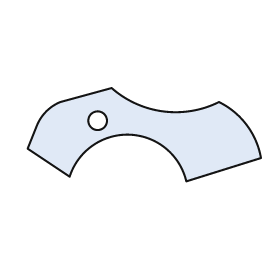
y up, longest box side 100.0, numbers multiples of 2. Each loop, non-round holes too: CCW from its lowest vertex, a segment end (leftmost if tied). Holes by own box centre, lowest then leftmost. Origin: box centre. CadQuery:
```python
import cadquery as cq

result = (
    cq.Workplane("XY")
    .moveTo(18.0, -20.0)
    .lineTo(50.0, -10.0)
    .threePointArc((44.0, 4.0), (32.0, 14.0))
    .threePointArc((8.0, 10.0), (-14.0, 20.0))
    .lineTo(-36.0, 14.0)
    .threePointArc((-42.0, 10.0), (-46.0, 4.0))
    .lineTo(-50.0, -6.0)
    .lineTo(-32.0, -18.0)
    .threePointArc((-6.0, 0.0), (18.0, -20.0))
    .close()
    .moveTo(-20.0, 6.0)
    .circle(4.0)
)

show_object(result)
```